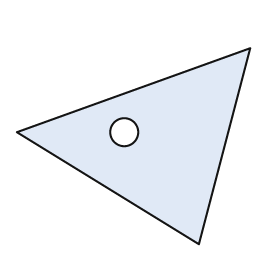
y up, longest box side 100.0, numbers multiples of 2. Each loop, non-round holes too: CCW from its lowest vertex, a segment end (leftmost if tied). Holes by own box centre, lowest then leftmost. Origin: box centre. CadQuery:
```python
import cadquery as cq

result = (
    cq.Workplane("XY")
    .moveTo(28.0, -42.0)
    .lineTo(50.0, 42.0)
    .lineTo(-50.0, 6.0)
    .close()
    .moveTo(-4.0, 6.0)
    .circle(6.0)
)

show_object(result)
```